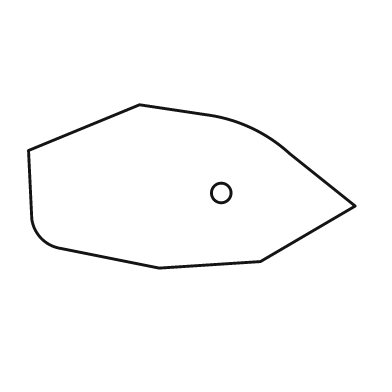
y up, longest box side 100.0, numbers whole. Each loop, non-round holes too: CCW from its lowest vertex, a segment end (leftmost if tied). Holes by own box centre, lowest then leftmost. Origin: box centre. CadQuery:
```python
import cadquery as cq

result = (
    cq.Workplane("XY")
    .moveTo(-10.0, -25.0)
    .lineTo(21.0, -23.0)
    .lineTo(50.0, -6.0)
    .lineTo(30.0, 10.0)
    .threePointArc((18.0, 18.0), (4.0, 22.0))
    .lineTo(-16.0, 25.0)
    .lineTo(-50.0, 11.0)
    .lineTo(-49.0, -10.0)
    .threePointArc((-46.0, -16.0), (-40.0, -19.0))
    .close()
    .moveTo(9.0, -2.0)
    .circle(3.0)
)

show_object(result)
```